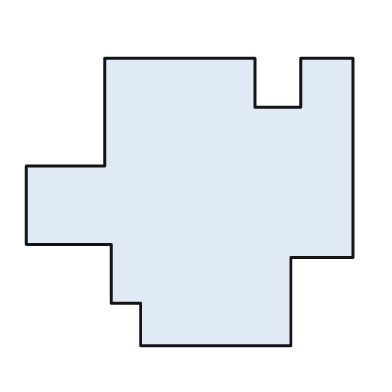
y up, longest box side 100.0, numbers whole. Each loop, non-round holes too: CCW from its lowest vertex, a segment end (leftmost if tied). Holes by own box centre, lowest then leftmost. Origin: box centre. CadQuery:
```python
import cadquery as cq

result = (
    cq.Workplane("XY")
    .moveTo(-15.0, -44.0)
    .lineTo(31.0, -44.0)
    .lineTo(31.0, -17.0)
    .lineTo(50.0, -17.0)
    .lineTo(50.0, 44.0)
    .lineTo(34.0, 44.0)
    .lineTo(34.0, 29.0)
    .lineTo(20.0, 29.0)
    .lineTo(20.0, 44.0)
    .lineTo(-26.0, 44.0)
    .lineTo(-26.0, 11.0)
    .lineTo(-50.0, 11.0)
    .lineTo(-50.0, -13.0)
    .lineTo(-24.0, -13.0)
    .lineTo(-24.0, -31.0)
    .lineTo(-15.0, -31.0)
    .close()
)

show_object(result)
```